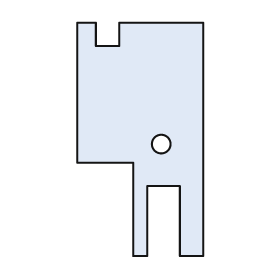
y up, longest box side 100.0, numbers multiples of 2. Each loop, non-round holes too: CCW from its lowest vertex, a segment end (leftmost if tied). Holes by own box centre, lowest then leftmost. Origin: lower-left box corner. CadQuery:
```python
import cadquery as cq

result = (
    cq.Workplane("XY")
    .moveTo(24.0, 0.0)
    .lineTo(30.0, 0.0)
    .lineTo(30.0, 30.0)
    .lineTo(44.0, 30.0)
    .lineTo(44.0, 0.0)
    .lineTo(54.0, 0.0)
    .lineTo(54.0, 100.0)
    .lineTo(18.0, 100.0)
    .lineTo(18.0, 90.0)
    .lineTo(8.0, 90.0)
    .lineTo(8.0, 100.0)
    .lineTo(0.0, 100.0)
    .lineTo(0.0, 40.0)
    .lineTo(24.0, 40.0)
    .close()
    .moveTo(36.0, 48.0)
    .circle(4.0)
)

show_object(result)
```